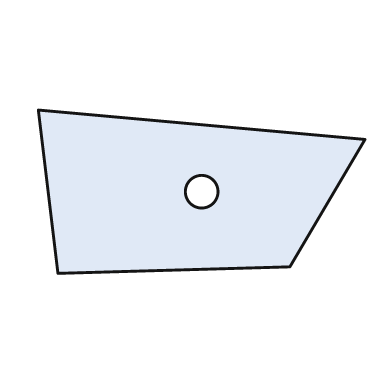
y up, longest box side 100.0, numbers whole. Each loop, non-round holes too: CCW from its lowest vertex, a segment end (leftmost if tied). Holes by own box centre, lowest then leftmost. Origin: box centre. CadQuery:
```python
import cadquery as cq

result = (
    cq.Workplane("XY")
    .moveTo(-44.0, -25.0)
    .lineTo(27.0, -23.0)
    .lineTo(50.0, 16.0)
    .lineTo(-50.0, 25.0)
    .close()
    .moveTo(0.0, 0.0)
    .circle(5.0)
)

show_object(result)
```